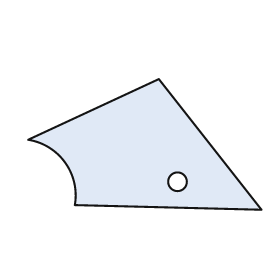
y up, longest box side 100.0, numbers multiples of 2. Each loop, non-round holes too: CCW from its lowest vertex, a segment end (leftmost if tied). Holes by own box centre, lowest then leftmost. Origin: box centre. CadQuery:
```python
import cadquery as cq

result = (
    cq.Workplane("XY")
    .moveTo(50.0, -28.0)
    .lineTo(6.0, 28.0)
    .lineTo(-50.0, 2.0)
    .threePointArc((-34.0, -8.0), (-30.0, -26.0))
    .close()
    .moveTo(14.0, -16.0)
    .circle(4.0)
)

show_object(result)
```